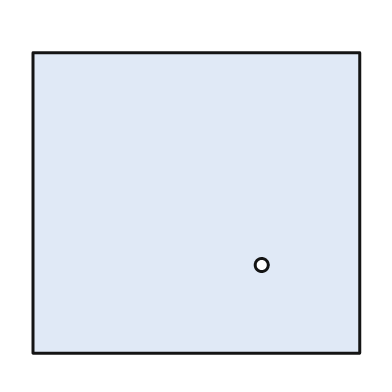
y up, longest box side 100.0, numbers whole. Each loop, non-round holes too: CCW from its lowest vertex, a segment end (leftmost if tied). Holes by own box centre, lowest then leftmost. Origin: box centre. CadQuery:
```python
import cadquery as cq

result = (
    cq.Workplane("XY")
    .moveTo(-50.0, -46.0)
    .lineTo(50.0, -46.0)
    .lineTo(50.0, 46.0)
    .lineTo(-50.0, 46.0)
    .close()
    .moveTo(20.0, -19.0)
    .circle(2.0)
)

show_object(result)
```